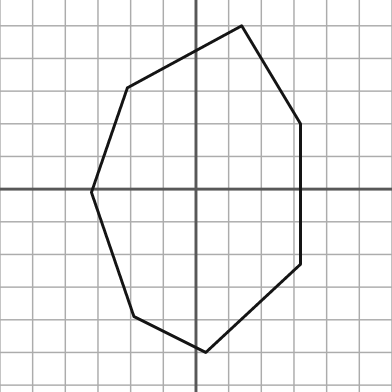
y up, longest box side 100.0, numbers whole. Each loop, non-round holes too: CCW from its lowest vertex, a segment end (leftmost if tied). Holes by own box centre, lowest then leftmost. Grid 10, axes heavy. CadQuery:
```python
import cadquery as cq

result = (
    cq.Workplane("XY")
    .moveTo(3.0, -50.0)
    .lineTo(32.0, -23.0)
    .lineTo(32.0, 20.0)
    .lineTo(14.0, 50.0)
    .lineTo(-21.0, 31.0)
    .lineTo(-32.0, -1.0)
    .lineTo(-19.0, -39.0)
    .close()
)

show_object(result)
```